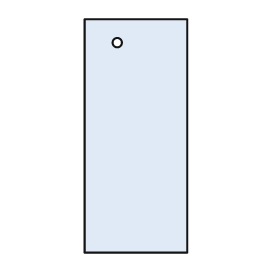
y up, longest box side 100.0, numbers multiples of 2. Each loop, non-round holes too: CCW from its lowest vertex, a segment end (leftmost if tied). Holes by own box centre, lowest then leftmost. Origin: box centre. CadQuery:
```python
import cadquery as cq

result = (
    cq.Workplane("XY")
    .moveTo(-22.0, -50.0)
    .lineTo(22.0, -50.0)
    .lineTo(22.0, 50.0)
    .lineTo(-22.0, 50.0)
    .close()
    .moveTo(-8.0, 40.0)
    .circle(2.0)
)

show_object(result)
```